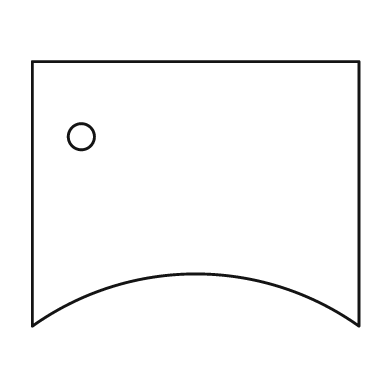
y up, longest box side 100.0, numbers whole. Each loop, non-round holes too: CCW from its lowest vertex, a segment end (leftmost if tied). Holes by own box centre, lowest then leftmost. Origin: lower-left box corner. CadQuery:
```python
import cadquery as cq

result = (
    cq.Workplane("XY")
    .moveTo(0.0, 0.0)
    .threePointArc((50.0, 16.0), (100.0, 0.0))
    .lineTo(100.0, 81.0)
    .lineTo(0.0, 81.0)
    .close()
    .moveTo(15.0, 58.0)
    .circle(4.0)
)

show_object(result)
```